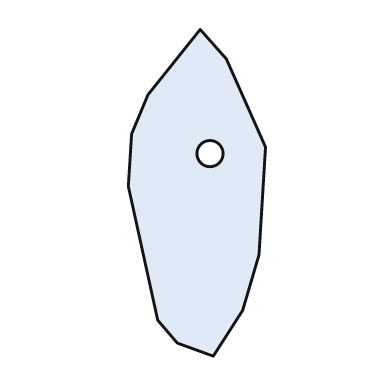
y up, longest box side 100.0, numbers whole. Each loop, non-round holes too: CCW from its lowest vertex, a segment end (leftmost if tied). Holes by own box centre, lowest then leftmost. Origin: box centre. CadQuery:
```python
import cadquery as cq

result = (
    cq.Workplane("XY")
    .moveTo(5.0, -50.0)
    .lineTo(14.0, -36.0)
    .lineTo(19.0, -19.0)
    .lineTo(21.0, 14.0)
    .lineTo(9.0, 41.0)
    .lineTo(1.0, 50.0)
    .lineTo(-15.0, 30.0)
    .lineTo(-20.0, 18.0)
    .lineTo(-21.0, 2.0)
    .lineTo(-12.0, -39.0)
    .lineTo(-6.0, -46.0)
    .close()
    .moveTo(4.0, 12.0)
    .circle(4.0)
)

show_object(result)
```